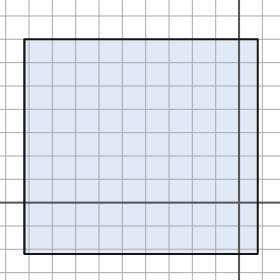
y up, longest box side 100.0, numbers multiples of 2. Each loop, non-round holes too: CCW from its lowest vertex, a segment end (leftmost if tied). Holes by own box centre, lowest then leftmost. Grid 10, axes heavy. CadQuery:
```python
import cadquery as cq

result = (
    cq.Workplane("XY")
    .moveTo(-92.0, -22.0)
    .lineTo(8.0, -22.0)
    .lineTo(8.0, 70.0)
    .lineTo(-92.0, 70.0)
    .close()
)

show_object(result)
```